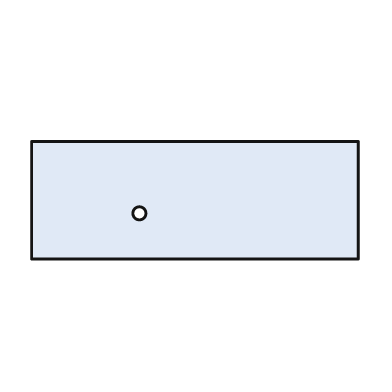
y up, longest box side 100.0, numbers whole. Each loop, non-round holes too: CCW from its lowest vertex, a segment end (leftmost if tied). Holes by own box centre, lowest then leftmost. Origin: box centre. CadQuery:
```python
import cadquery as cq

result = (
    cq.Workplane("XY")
    .moveTo(-50.0, -18.0)
    .lineTo(50.0, -18.0)
    .lineTo(50.0, 18.0)
    .lineTo(-50.0, 18.0)
    .close()
    .moveTo(-17.0, -4.0)
    .circle(2.0)
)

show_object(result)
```